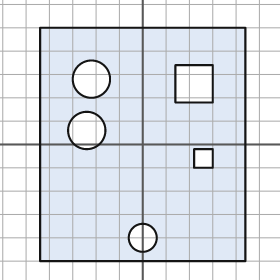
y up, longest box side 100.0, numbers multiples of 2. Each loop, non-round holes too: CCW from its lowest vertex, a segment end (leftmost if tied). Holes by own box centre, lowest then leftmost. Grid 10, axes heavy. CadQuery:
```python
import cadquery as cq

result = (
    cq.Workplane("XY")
    .moveTo(-44.0, -50.0)
    .lineTo(44.0, -50.0)
    .lineTo(44.0, 50.0)
    .lineTo(-44.0, 50.0)
    .close()
    .moveTo(0.0, -40.0)
    .circle(6.0)
    .moveTo(22.0, -10.0)
    .lineTo(30.0, -10.0)
    .lineTo(30.0, -2.0)
    .lineTo(22.0, -2.0)
    .close()
    .moveTo(-24.0, 6.0)
    .circle(8.0)
    .moveTo(14.0, 18.0)
    .lineTo(30.0, 18.0)
    .lineTo(30.0, 34.0)
    .lineTo(14.0, 34.0)
    .close()
    .moveTo(-22.0, 28.0)
    .circle(8.0)
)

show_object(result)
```